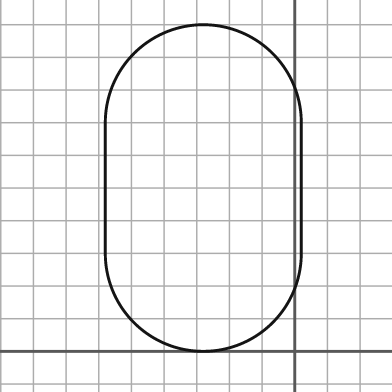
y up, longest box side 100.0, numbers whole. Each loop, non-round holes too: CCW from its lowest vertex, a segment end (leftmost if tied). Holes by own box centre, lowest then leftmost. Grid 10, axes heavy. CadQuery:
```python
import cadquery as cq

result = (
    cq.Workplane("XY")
    .moveTo(-58.0, 30.0)
    .threePointArc((-28.0, 0.0), (2.0, 30.0))
    .lineTo(2.0, 70.0)
    .threePointArc((-28.0, 100.0), (-58.0, 70.0))
    .close()
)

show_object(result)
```